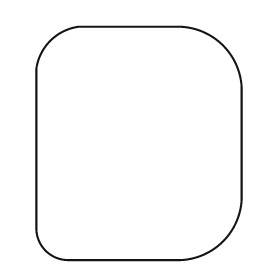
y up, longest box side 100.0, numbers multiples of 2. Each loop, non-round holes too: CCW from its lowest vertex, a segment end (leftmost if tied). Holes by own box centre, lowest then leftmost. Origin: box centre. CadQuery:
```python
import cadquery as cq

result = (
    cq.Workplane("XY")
    .moveTo(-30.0, -50.0)
    .lineTo(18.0, -50.0)
    .threePointArc((36.0, -42.0), (44.0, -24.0))
    .lineTo(44.0, 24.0)
    .threePointArc((36.0, 42.0), (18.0, 50.0))
    .lineTo(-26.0, 50.0)
    .threePointArc((-38.0, 44.0), (-44.0, 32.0))
    .lineTo(-44.0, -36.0)
    .threePointArc((-40.0, -46.0), (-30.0, -50.0))
    .close()
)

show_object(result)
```